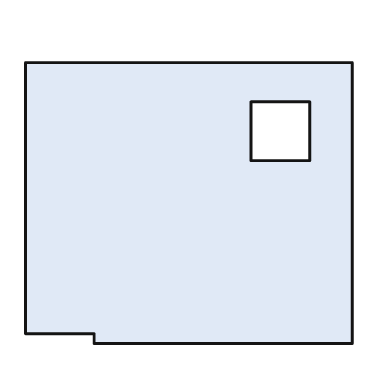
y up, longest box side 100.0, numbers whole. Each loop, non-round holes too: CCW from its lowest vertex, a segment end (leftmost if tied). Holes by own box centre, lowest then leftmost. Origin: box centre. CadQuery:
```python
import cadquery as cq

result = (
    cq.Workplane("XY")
    .moveTo(-29.0, -43.0)
    .lineTo(50.0, -43.0)
    .lineTo(50.0, 43.0)
    .lineTo(-50.0, 43.0)
    .lineTo(-50.0, -40.0)
    .lineTo(-29.0, -40.0)
    .close()
    .moveTo(19.0, 13.0)
    .lineTo(37.0, 13.0)
    .lineTo(37.0, 31.0)
    .lineTo(19.0, 31.0)
    .close()
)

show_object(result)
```